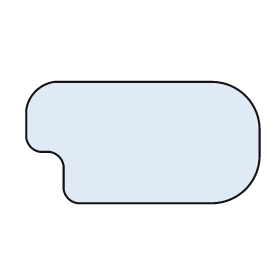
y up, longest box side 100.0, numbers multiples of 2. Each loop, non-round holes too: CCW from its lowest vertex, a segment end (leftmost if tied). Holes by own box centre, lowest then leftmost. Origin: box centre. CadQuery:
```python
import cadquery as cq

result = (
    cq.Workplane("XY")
    .moveTo(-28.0, -26.0)
    .lineTo(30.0, -26.0)
    .threePointArc((44.0, -20.0), (50.0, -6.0))
    .lineTo(50.0, 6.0)
    .threePointArc((44.0, 20.0), (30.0, 26.0))
    .lineTo(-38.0, 26.0)
    .threePointArc((-46.0, 22.0), (-50.0, 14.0))
    .lineTo(-50.0, 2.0)
    .threePointArc((-48.0, -2.0), (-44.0, -4.0))
    .lineTo(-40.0, -4.0)
    .threePointArc((-36.0, -6.0), (-34.0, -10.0))
    .lineTo(-34.0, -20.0)
    .threePointArc((-32.0, -24.0), (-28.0, -26.0))
    .close()
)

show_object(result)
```